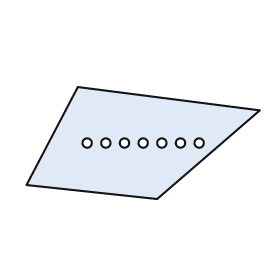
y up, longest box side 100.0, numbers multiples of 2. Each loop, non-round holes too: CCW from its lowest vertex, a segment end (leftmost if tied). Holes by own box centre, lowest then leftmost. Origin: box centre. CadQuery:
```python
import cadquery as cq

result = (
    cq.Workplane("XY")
    .moveTo(6.0, -24.0)
    .lineTo(50.0, 14.0)
    .lineTo(-28.0, 24.0)
    .lineTo(-50.0, -18.0)
    .close()
    .moveTo(-24.0, 0.0)
    .circle(2.0)
    .moveTo(-16.0, 0.0)
    .circle(2.0)
    .moveTo(-8.0, 0.0)
    .circle(2.0)
    .moveTo(0.0, 0.0)
    .circle(2.0)
    .moveTo(8.0, 0.0)
    .circle(2.0)
    .moveTo(16.0, 0.0)
    .circle(2.0)
    .moveTo(24.0, 0.0)
    .circle(2.0)
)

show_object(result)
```